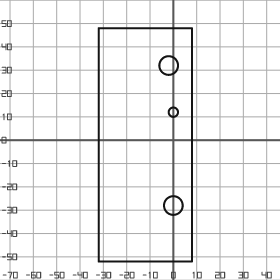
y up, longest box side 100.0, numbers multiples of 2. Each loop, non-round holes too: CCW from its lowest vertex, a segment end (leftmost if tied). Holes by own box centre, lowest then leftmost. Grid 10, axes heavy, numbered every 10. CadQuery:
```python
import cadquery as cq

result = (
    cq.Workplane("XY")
    .moveTo(-32.0, -52.0)
    .lineTo(8.0, -52.0)
    .lineTo(8.0, 48.0)
    .lineTo(-32.0, 48.0)
    .close()
    .moveTo(0.0, -28.0)
    .circle(4.0)
    .moveTo(0.0, 12.0)
    .circle(2.0)
    .moveTo(-2.0, 32.0)
    .circle(4.0)
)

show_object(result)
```